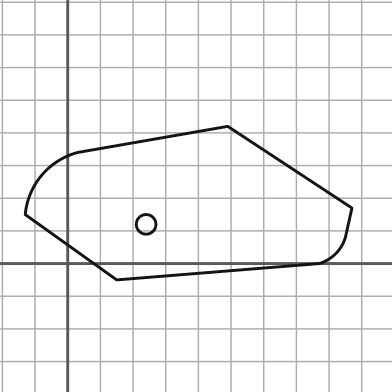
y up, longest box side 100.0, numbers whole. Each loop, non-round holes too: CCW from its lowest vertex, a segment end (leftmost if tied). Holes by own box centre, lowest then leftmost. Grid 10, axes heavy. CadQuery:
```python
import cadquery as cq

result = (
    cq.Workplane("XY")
    .moveTo(15.0, -5.0)
    .lineTo(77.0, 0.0)
    .threePointArc((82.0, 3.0), (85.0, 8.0))
    .lineTo(87.0, 17.0)
    .lineTo(49.0, 42.0)
    .lineTo(3.0, 34.0)
    .threePointArc((-8.0, 27.0), (-13.0, 15.0))
    .close()
    .moveTo(24.0, 12.0)
    .circle(3.0)
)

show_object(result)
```